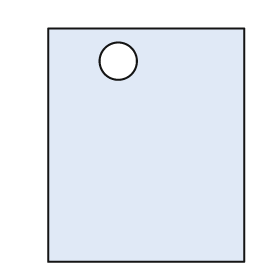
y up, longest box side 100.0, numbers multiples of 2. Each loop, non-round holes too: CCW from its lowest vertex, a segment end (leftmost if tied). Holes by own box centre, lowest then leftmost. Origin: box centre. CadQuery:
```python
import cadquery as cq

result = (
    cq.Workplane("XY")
    .moveTo(-42.0, -50.0)
    .lineTo(42.0, -50.0)
    .lineTo(42.0, 50.0)
    .lineTo(-42.0, 50.0)
    .close()
    .moveTo(-12.0, 36.0)
    .circle(8.0)
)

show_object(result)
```